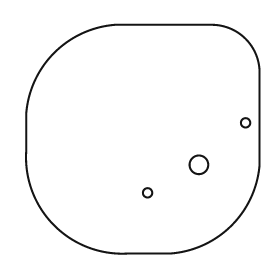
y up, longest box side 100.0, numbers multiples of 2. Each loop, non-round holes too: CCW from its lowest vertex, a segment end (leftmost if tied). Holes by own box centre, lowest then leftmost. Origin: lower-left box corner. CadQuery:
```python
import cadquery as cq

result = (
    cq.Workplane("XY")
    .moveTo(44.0, 0.0)
    .lineTo(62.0, 0.0)
    .threePointArc((88.0, 12.0), (100.0, 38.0))
    .lineTo(100.0, 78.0)
    .threePointArc((94.0, 92.0), (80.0, 98.0))
    .lineTo(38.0, 98.0)
    .threePointArc((12.0, 86.0), (0.0, 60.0))
    .lineTo(0.0, 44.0)
    .threePointArc((12.0, 12.0), (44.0, 0.0))
    .close()
    .moveTo(52.0, 26.0)
    .circle(2.0)
    .moveTo(74.0, 38.0)
    .circle(4.0)
    .moveTo(94.0, 56.0)
    .circle(2.0)
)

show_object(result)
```